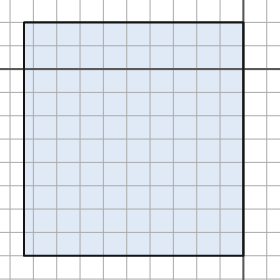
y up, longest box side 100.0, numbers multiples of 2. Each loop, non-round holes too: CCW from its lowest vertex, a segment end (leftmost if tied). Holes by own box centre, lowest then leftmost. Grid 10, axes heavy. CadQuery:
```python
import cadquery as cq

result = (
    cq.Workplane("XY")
    .moveTo(-94.0, -80.0)
    .lineTo(0.0, -80.0)
    .lineTo(0.0, 20.0)
    .lineTo(-94.0, 20.0)
    .close()
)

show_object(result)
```